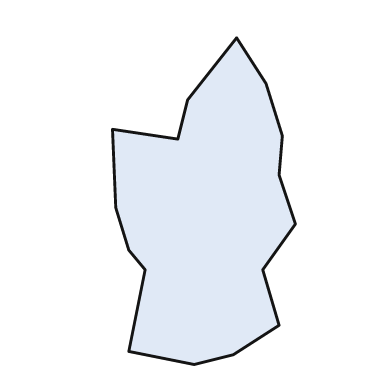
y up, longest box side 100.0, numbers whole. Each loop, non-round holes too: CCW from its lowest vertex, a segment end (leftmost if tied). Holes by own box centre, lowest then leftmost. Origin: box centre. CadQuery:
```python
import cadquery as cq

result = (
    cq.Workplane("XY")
    .moveTo(-3.0, -50.0)
    .lineTo(9.0, -47.0)
    .lineTo(23.0, -38.0)
    .lineTo(18.0, -21.0)
    .lineTo(28.0, -7.0)
    .lineTo(23.0, 8.0)
    .lineTo(24.0, 20.0)
    .lineTo(19.0, 36.0)
    .lineTo(10.0, 50.0)
    .lineTo(-5.0, 31.0)
    .lineTo(-8.0, 19.0)
    .lineTo(-28.0, 22.0)
    .lineTo(-27.0, -2.0)
    .lineTo(-23.0, -15.0)
    .lineTo(-18.0, -21.0)
    .lineTo(-23.0, -46.0)
    .close()
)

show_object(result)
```